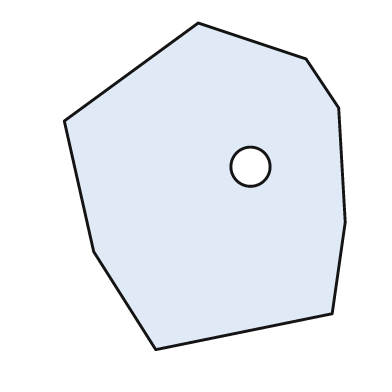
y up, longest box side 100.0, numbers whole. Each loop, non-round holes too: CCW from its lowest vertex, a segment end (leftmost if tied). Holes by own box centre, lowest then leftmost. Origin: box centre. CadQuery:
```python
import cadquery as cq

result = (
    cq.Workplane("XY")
    .moveTo(-15.0, -50.0)
    .lineTo(39.0, -39.0)
    .lineTo(43.0, -11.0)
    .lineTo(41.0, 24.0)
    .lineTo(31.0, 39.0)
    .lineTo(-2.0, 50.0)
    .lineTo(-43.0, 20.0)
    .lineTo(-34.0, -20.0)
    .close()
    .moveTo(14.0, 6.0)
    .circle(6.0)
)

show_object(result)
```